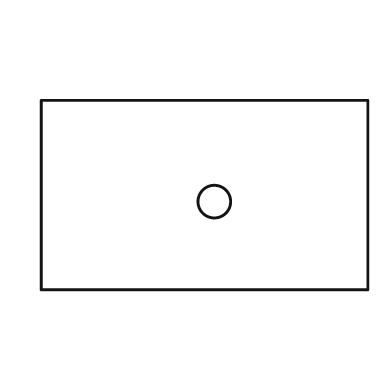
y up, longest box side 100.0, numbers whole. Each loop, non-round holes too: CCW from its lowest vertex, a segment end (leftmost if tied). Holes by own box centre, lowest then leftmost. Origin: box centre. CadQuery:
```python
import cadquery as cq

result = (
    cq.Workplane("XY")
    .moveTo(-50.0, -29.0)
    .lineTo(50.0, -29.0)
    .lineTo(50.0, 29.0)
    .lineTo(-50.0, 29.0)
    .close()
    .moveTo(3.0, -2.0)
    .circle(5.0)
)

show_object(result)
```